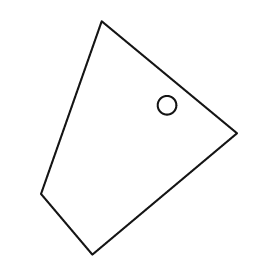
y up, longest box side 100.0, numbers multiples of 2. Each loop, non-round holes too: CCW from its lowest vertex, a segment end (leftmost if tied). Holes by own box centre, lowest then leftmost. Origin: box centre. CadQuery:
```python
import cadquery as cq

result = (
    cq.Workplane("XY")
    .moveTo(-20.0, -50.0)
    .lineTo(42.0, 2.0)
    .lineTo(-16.0, 50.0)
    .lineTo(-42.0, -24.0)
    .close()
    .moveTo(12.0, 14.0)
    .circle(4.0)
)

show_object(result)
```